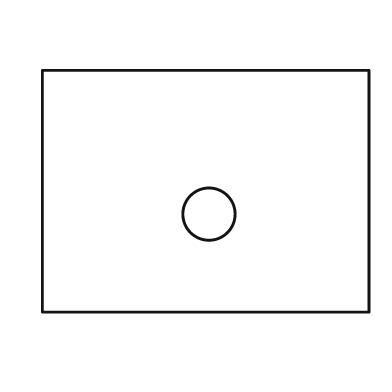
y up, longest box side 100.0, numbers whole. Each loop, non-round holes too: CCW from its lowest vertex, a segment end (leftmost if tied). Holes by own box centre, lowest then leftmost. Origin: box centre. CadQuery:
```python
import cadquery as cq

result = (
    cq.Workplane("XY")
    .moveTo(-50.0, -37.0)
    .lineTo(50.0, -37.0)
    .lineTo(50.0, 37.0)
    .lineTo(-50.0, 37.0)
    .close()
    .moveTo(1.0, -7.0)
    .circle(8.0)
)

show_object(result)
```